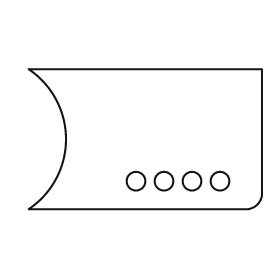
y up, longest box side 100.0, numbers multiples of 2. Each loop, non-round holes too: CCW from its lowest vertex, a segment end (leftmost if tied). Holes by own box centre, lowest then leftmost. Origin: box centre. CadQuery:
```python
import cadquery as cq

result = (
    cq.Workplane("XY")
    .moveTo(-50.0, -30.0)
    .lineTo(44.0, -30.0)
    .threePointArc((48.0, -28.0), (50.0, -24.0))
    .lineTo(50.0, 30.0)
    .lineTo(-50.0, 30.0)
    .threePointArc((-34.0, 0.0), (-50.0, -30.0))
    .close()
    .moveTo(-4.0, -18.0)
    .circle(4.0)
    .moveTo(8.0, -18.0)
    .circle(4.0)
    .moveTo(20.0, -18.0)
    .circle(4.0)
    .moveTo(32.0, -18.0)
    .circle(4.0)
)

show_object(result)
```